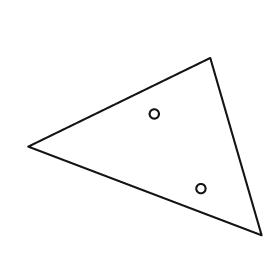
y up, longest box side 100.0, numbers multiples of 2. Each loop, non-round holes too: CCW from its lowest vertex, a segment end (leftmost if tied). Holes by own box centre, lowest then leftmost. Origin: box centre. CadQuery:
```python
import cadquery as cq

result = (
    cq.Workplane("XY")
    .moveTo(50.0, -38.0)
    .lineTo(28.0, 38.0)
    .lineTo(-50.0, 0.0)
    .close()
    .moveTo(24.0, -18.0)
    .circle(2.0)
    .moveTo(4.0, 14.0)
    .circle(2.0)
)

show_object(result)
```